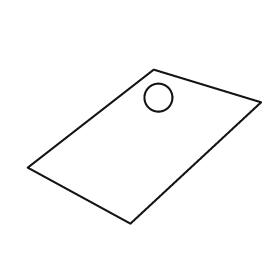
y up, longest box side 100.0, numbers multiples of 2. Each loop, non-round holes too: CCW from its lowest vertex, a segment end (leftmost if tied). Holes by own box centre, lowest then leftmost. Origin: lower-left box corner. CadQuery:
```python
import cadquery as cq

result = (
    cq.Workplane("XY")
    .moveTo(44.0, 0.0)
    .lineTo(100.0, 52.0)
    .lineTo(54.0, 66.0)
    .lineTo(0.0, 24.0)
    .close()
    .moveTo(56.0, 54.0)
    .circle(6.0)
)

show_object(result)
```